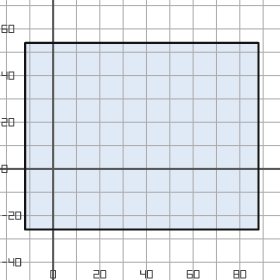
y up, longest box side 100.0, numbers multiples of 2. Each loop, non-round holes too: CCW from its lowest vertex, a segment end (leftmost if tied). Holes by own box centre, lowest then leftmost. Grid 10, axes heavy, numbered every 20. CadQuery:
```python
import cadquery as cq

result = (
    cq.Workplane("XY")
    .moveTo(-12.0, -26.0)
    .lineTo(88.0, -26.0)
    .lineTo(88.0, 54.0)
    .lineTo(-12.0, 54.0)
    .close()
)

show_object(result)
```